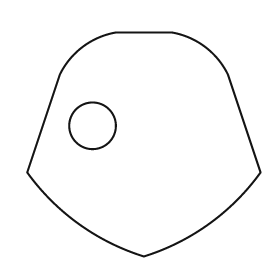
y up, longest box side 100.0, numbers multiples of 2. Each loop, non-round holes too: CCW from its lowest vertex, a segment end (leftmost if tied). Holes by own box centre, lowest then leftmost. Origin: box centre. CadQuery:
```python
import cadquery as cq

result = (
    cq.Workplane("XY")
    .moveTo(0.0, -48.0)
    .threePointArc((28.0, -34.0), (50.0, -12.0))
    .lineTo(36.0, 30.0)
    .threePointArc((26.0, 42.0), (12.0, 48.0))
    .lineTo(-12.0, 48.0)
    .threePointArc((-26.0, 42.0), (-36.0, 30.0))
    .lineTo(-50.0, -12.0)
    .threePointArc((-28.0, -34.0), (0.0, -48.0))
    .close()
    .moveTo(-22.0, 8.0)
    .circle(10.0)
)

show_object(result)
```